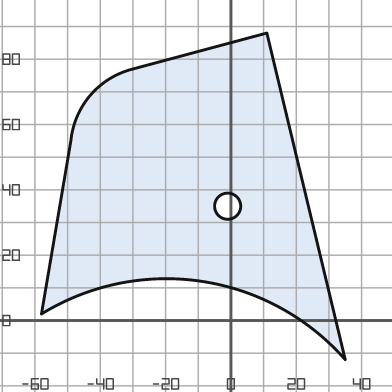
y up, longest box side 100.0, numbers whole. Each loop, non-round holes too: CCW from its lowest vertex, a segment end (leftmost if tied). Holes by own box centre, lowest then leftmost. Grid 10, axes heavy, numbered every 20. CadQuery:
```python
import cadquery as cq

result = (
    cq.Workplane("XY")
    .moveTo(35.0, -12.0)
    .lineTo(11.0, 88.0)
    .lineTo(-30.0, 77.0)
    .threePointArc((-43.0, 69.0), (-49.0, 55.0))
    .lineTo(-58.0, 2.0)
    .threePointArc((-9.0, 12.0), (35.0, -12.0))
    .close()
    .moveTo(-1.0, 35.0)
    .circle(4.0)
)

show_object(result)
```